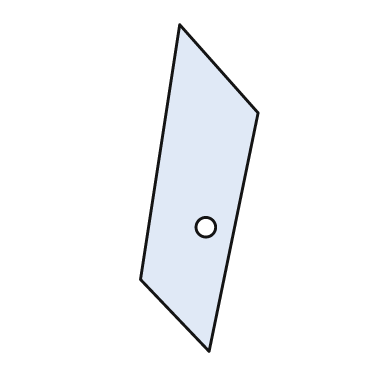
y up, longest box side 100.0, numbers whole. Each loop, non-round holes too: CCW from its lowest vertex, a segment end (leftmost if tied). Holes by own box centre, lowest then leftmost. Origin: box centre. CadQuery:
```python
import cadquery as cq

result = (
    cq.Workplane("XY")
    .moveTo(3.0, -50.0)
    .lineTo(18.0, 23.0)
    .lineTo(-6.0, 50.0)
    .lineTo(-18.0, -28.0)
    .close()
    .moveTo(2.0, -12.0)
    .circle(3.0)
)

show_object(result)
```